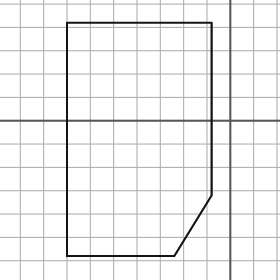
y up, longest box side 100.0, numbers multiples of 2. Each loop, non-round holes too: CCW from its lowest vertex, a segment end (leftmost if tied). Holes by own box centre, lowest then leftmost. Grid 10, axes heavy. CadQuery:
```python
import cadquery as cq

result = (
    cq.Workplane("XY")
    .moveTo(-70.0, -58.0)
    .lineTo(-24.0, -58.0)
    .lineTo(-8.0, -32.0)
    .lineTo(-8.0, 42.0)
    .lineTo(-70.0, 42.0)
    .close()
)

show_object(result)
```